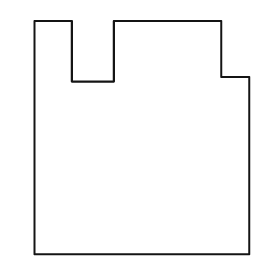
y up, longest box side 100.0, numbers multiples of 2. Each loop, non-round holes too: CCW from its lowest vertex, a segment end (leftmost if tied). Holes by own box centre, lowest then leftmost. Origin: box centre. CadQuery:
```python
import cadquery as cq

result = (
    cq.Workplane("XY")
    .moveTo(-46.0, -50.0)
    .lineTo(46.0, -50.0)
    .lineTo(46.0, 26.0)
    .lineTo(34.0, 26.0)
    .lineTo(34.0, 50.0)
    .lineTo(-12.0, 50.0)
    .lineTo(-12.0, 24.0)
    .lineTo(-30.0, 24.0)
    .lineTo(-30.0, 50.0)
    .lineTo(-46.0, 50.0)
    .close()
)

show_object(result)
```